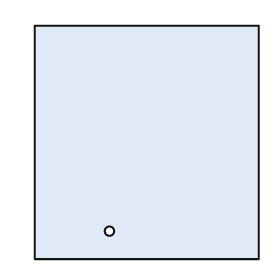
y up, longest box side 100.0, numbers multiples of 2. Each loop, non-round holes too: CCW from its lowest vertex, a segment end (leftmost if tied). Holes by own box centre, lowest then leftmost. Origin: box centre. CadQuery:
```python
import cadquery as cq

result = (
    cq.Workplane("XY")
    .moveTo(-48.0, -50.0)
    .lineTo(48.0, -50.0)
    .lineTo(48.0, 50.0)
    .lineTo(-48.0, 50.0)
    .close()
    .moveTo(-16.0, -38.0)
    .circle(2.0)
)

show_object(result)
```